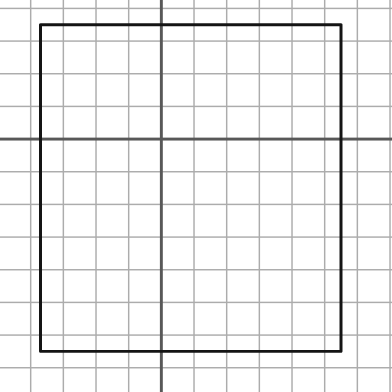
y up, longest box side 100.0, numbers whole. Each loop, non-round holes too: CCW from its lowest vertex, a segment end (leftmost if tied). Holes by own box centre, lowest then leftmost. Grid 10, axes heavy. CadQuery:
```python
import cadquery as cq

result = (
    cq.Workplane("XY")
    .moveTo(-37.0, -65.0)
    .lineTo(55.0, -65.0)
    .lineTo(55.0, 35.0)
    .lineTo(-37.0, 35.0)
    .close()
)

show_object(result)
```